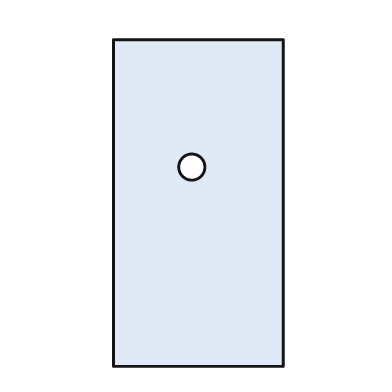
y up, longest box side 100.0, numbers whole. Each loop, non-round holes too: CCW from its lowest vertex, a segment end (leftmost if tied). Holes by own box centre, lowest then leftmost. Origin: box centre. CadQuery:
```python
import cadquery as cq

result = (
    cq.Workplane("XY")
    .moveTo(-26.0, -50.0)
    .lineTo(26.0, -50.0)
    .lineTo(26.0, 50.0)
    .lineTo(-26.0, 50.0)
    .close()
    .moveTo(-2.0, 11.0)
    .circle(4.0)
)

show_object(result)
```